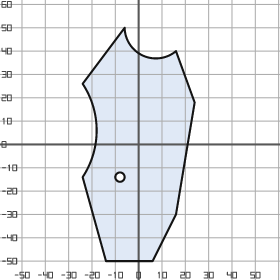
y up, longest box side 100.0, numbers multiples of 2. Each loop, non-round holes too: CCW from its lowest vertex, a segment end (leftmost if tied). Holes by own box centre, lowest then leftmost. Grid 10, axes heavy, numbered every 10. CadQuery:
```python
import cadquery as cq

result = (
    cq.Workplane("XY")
    .moveTo(-14.0, -50.0)
    .lineTo(6.0, -50.0)
    .lineTo(16.0, -30.0)
    .lineTo(24.0, 18.0)
    .lineTo(16.0, 40.0)
    .threePointArc((2.0, 38.0), (-6.0, 50.0))
    .lineTo(-24.0, 26.0)
    .threePointArc((-18.0, 6.0), (-24.0, -14.0))
    .close()
    .moveTo(-8.0, -14.0)
    .circle(2.0)
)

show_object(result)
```